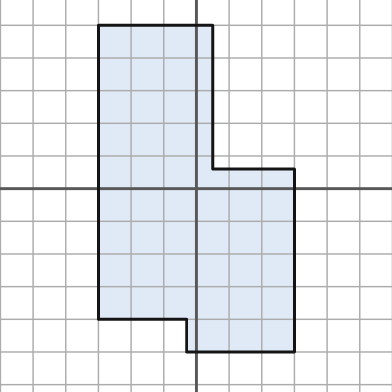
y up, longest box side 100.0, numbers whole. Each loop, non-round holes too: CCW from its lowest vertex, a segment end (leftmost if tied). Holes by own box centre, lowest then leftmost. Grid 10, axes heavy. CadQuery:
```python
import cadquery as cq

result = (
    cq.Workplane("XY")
    .moveTo(-3.0, -50.0)
    .lineTo(30.0, -50.0)
    .lineTo(30.0, 6.0)
    .lineTo(5.0, 6.0)
    .lineTo(5.0, 50.0)
    .lineTo(-30.0, 50.0)
    .lineTo(-30.0, -40.0)
    .lineTo(-3.0, -40.0)
    .close()
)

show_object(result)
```